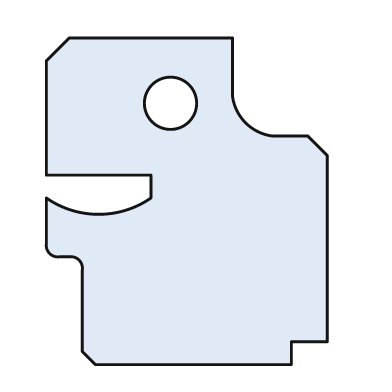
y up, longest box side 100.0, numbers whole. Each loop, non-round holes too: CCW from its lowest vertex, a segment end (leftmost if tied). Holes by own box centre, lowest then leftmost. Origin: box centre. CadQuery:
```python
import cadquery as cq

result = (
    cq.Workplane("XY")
    .moveTo(-28.0, -50.0)
    .lineTo(32.0, -50.0)
    .lineTo(32.0, -43.0)
    .lineTo(43.0, -43.0)
    .lineTo(43.0, 14.0)
    .lineTo(37.0, 20.0)
    .lineTo(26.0, 20.0)
    .threePointArc((18.0, 24.0), (14.0, 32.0))
    .lineTo(14.0, 50.0)
    .lineTo(-36.0, 50.0)
    .lineTo(-43.0, 43.0)
    .lineTo(-43.0, 8.0)
    .lineTo(-11.0, 8.0)
    .lineTo(-11.0, 1.0)
    .threePointArc((-27.0, -4.0), (-43.0, 1.0))
    .lineTo(-43.0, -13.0)
    .threePointArc((-42.0, -16.0), (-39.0, -17.0))
    .lineTo(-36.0, -17.0)
    .threePointArc((-33.0, -18.0), (-32.0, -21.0))
    .lineTo(-32.0, -46.0)
    .close()
    .moveTo(-5.0, 30.0)
    .circle(8.0)
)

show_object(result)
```